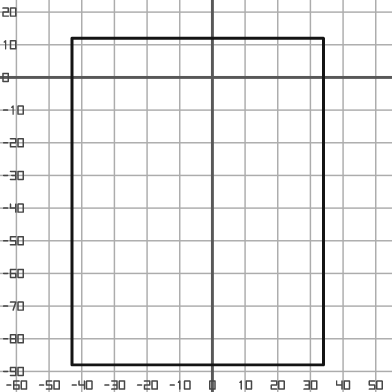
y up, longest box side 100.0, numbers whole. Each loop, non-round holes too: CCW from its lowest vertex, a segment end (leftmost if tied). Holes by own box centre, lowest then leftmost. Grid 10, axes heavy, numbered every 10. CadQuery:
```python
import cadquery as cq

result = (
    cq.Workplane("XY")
    .moveTo(-43.0, -88.0)
    .lineTo(34.0, -88.0)
    .lineTo(34.0, 12.0)
    .lineTo(-43.0, 12.0)
    .close()
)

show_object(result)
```